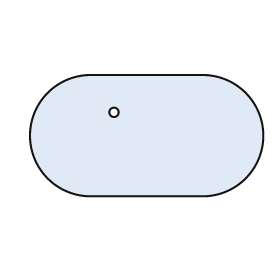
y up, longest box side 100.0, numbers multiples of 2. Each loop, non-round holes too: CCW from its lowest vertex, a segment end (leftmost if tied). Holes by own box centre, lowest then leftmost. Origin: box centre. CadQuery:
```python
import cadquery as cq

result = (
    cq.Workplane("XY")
    .moveTo(-24.0, -26.0)
    .lineTo(24.0, -26.0)
    .threePointArc((50.0, 0.0), (24.0, 26.0))
    .lineTo(-24.0, 26.0)
    .threePointArc((-50.0, 0.0), (-24.0, -26.0))
    .close()
    .moveTo(-14.0, 10.0)
    .circle(2.0)
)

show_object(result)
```